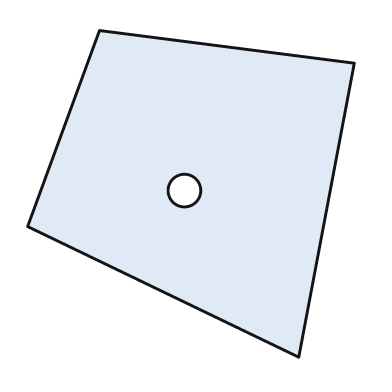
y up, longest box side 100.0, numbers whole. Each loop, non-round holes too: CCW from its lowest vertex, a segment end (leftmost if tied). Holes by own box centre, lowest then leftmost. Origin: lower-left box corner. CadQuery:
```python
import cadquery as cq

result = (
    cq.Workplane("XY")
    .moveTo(83.0, 0.0)
    .lineTo(100.0, 90.0)
    .lineTo(22.0, 100.0)
    .lineTo(0.0, 40.0)
    .close()
    .moveTo(48.0, 51.0)
    .circle(5.0)
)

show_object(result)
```